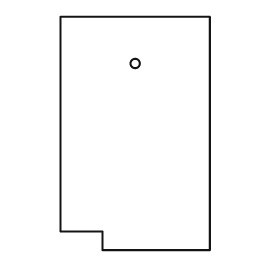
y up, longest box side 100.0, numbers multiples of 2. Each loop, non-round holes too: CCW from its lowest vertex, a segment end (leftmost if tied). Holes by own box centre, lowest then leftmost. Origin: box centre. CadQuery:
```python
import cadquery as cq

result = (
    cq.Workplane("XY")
    .moveTo(-14.0, -50.0)
    .lineTo(32.0, -50.0)
    .lineTo(32.0, 50.0)
    .lineTo(-32.0, 50.0)
    .lineTo(-32.0, -42.0)
    .lineTo(-14.0, -42.0)
    .close()
    .moveTo(0.0, 30.0)
    .circle(2.0)
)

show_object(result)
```